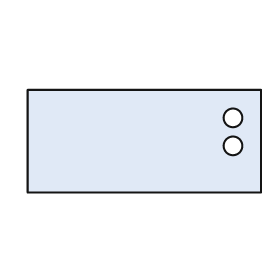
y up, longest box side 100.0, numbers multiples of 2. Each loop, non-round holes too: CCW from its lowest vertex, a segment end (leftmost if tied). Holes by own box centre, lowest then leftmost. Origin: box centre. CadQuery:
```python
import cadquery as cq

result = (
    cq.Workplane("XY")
    .moveTo(-50.0, -22.0)
    .lineTo(50.0, -22.0)
    .lineTo(50.0, 22.0)
    .lineTo(-50.0, 22.0)
    .close()
    .moveTo(38.0, -2.0)
    .circle(4.0)
    .moveTo(38.0, 10.0)
    .circle(4.0)
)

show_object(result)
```